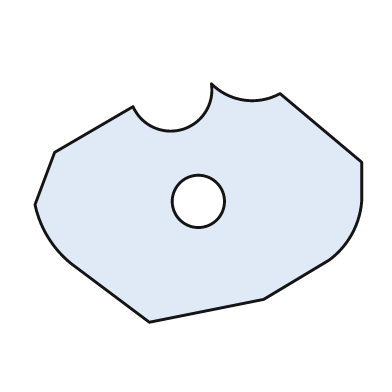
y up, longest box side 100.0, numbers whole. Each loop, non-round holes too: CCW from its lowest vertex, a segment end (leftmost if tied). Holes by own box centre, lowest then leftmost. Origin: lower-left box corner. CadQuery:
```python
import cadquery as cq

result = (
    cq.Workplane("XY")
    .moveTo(35.0, 0.0)
    .lineTo(70.0, 7.0)
    .lineTo(90.0, 19.0)
    .threePointArc((97.0, 27.0), (100.0, 37.0))
    .lineTo(100.0, 49.0)
    .lineTo(75.0, 70.0)
    .threePointArc((64.0, 68.0), (54.0, 73.0))
    .threePointArc((45.0, 59.0), (30.0, 66.0))
    .lineTo(6.0, 52.0)
    .lineTo(0.0, 36.0)
    .threePointArc((4.0, 26.0), (11.0, 18.0))
    .close()
    .moveTo(50.0, 37.0)
    .circle(8.0)
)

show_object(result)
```